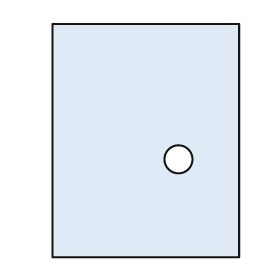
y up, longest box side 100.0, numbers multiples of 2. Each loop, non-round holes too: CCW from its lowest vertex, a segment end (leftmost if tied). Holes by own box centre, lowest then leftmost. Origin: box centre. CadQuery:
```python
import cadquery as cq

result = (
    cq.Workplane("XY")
    .moveTo(-40.0, -50.0)
    .lineTo(40.0, -50.0)
    .lineTo(40.0, 50.0)
    .lineTo(-40.0, 50.0)
    .close()
    .moveTo(14.0, -8.0)
    .circle(6.0)
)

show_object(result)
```